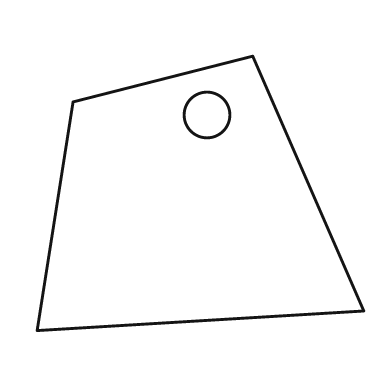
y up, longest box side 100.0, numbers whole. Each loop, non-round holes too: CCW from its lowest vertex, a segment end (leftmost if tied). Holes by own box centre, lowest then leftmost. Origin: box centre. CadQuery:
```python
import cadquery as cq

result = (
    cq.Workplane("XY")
    .moveTo(-50.0, -42.0)
    .lineTo(50.0, -36.0)
    .lineTo(16.0, 42.0)
    .lineTo(-39.0, 28.0)
    .close()
    .moveTo(2.0, 24.0)
    .circle(7.0)
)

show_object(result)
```